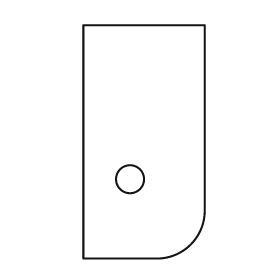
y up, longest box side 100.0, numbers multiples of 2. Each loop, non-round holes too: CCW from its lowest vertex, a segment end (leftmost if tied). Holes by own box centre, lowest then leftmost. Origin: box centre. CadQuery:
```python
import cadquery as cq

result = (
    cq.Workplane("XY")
    .moveTo(-26.0, -50.0)
    .lineTo(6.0, -50.0)
    .threePointArc((20.0, -44.0), (26.0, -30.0))
    .lineTo(26.0, 50.0)
    .lineTo(-26.0, 50.0)
    .close()
    .moveTo(-6.0, -16.0)
    .circle(6.0)
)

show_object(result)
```